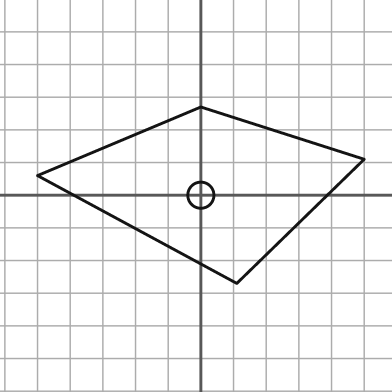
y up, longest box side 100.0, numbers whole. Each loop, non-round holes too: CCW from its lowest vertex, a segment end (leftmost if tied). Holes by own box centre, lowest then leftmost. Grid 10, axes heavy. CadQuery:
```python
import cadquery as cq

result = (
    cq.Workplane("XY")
    .moveTo(11.0, -27.0)
    .lineTo(50.0, 11.0)
    .lineTo(0.0, 27.0)
    .lineTo(-50.0, 6.0)
    .close()
    .moveTo(0.0, 0.0)
    .circle(4.0)
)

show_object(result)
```